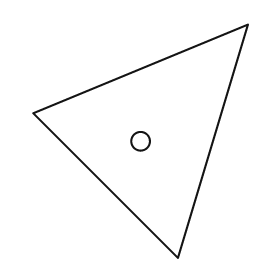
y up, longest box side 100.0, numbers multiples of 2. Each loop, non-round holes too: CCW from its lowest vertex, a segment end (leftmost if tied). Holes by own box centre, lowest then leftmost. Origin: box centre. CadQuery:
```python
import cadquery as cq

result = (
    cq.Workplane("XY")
    .moveTo(16.0, -50.0)
    .lineTo(46.0, 50.0)
    .lineTo(-46.0, 12.0)
    .close()
    .moveTo(0.0, 0.0)
    .circle(4.0)
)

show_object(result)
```